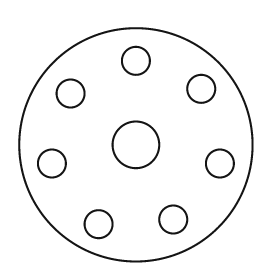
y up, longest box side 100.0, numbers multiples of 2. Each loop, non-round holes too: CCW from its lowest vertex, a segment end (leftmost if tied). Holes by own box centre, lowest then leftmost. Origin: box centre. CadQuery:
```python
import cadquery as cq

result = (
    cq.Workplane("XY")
    .moveTo(0.0, 0.0)
    .circle(50.0)
    .moveTo(-16.0, -34.0)
    .circle(6.0)
    .moveTo(16.0, -32.0)
    .circle(6.0)
    .moveTo(-36.0, -8.0)
    .circle(6.0)
    .moveTo(36.0, -8.0)
    .circle(6.0)
    .moveTo(0.0, 0.0)
    .circle(10.0)
    .moveTo(-28.0, 22.0)
    .circle(6.0)
    .moveTo(28.0, 24.0)
    .circle(6.0)
    .moveTo(0.0, 36.0)
    .circle(6.0)
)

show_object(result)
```